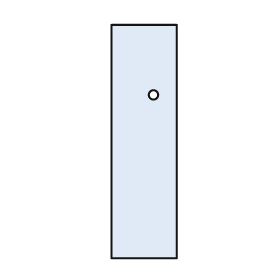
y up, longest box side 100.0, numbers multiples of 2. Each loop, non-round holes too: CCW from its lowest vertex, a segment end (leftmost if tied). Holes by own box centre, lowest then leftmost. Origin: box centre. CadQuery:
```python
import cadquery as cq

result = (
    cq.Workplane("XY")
    .moveTo(-14.0, -50.0)
    .lineTo(14.0, -50.0)
    .lineTo(14.0, 50.0)
    .lineTo(-14.0, 50.0)
    .close()
    .moveTo(4.0, 20.0)
    .circle(2.0)
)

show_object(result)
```